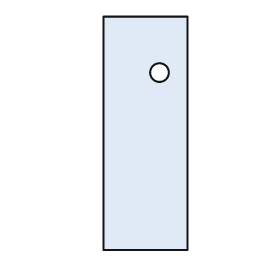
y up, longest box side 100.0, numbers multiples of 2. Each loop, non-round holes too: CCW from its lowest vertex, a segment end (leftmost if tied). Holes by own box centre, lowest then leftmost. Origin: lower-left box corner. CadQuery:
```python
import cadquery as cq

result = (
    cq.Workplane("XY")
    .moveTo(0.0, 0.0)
    .lineTo(36.0, 0.0)
    .lineTo(36.0, 100.0)
    .lineTo(0.0, 100.0)
    .close()
    .moveTo(24.0, 76.0)
    .circle(4.0)
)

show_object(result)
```